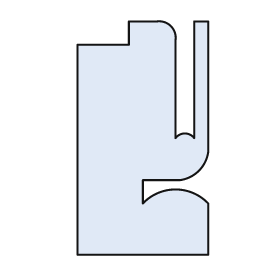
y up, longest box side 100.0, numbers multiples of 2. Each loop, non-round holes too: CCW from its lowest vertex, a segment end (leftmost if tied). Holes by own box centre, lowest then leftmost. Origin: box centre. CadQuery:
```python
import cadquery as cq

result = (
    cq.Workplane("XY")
    .moveTo(-28.0, -50.0)
    .lineTo(28.0, -50.0)
    .lineTo(28.0, -28.0)
    .threePointArc((14.0, -22.0), (0.0, -28.0))
    .lineTo(0.0, -18.0)
    .lineTo(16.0, -18.0)
    .threePointArc((24.0, -14.0), (28.0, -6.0))
    .lineTo(28.0, 50.0)
    .lineTo(22.0, 50.0)
    .lineTo(22.0, 0.0)
    .threePointArc((18.0, 2.0), (14.0, 0.0))
    .lineTo(14.0, 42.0)
    .threePointArc((12.0, 48.0), (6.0, 50.0))
    .lineTo(-6.0, 50.0)
    .lineTo(-6.0, 40.0)
    .lineTo(-28.0, 40.0)
    .close()
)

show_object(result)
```